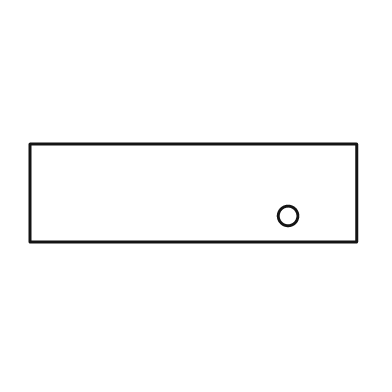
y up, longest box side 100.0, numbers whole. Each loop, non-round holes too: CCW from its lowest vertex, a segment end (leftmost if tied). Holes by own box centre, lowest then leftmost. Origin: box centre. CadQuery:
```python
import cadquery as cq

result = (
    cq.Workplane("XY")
    .moveTo(-50.0, -15.0)
    .lineTo(50.0, -15.0)
    .lineTo(50.0, 15.0)
    .lineTo(-50.0, 15.0)
    .close()
    .moveTo(29.0, -7.0)
    .circle(3.0)
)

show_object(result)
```